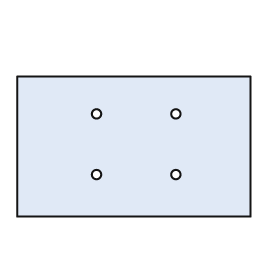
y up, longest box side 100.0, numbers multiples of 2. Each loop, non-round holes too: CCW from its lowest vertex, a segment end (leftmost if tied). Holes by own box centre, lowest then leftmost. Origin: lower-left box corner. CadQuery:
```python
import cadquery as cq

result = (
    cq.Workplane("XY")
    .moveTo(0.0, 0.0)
    .lineTo(100.0, 0.0)
    .lineTo(100.0, 60.0)
    .lineTo(0.0, 60.0)
    .close()
    .moveTo(34.0, 18.0)
    .circle(2.0)
    .moveTo(68.0, 18.0)
    .circle(2.0)
    .moveTo(34.0, 44.0)
    .circle(2.0)
    .moveTo(68.0, 44.0)
    .circle(2.0)
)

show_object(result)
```